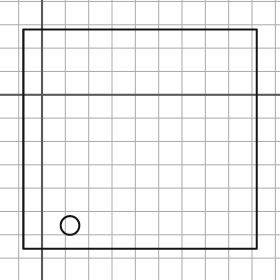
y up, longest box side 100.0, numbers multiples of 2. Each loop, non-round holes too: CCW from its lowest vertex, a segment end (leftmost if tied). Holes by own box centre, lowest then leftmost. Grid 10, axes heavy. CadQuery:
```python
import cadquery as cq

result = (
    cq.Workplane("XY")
    .moveTo(-8.0, -66.0)
    .lineTo(92.0, -66.0)
    .lineTo(92.0, 28.0)
    .lineTo(-8.0, 28.0)
    .close()
    .moveTo(12.0, -56.0)
    .circle(4.0)
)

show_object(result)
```